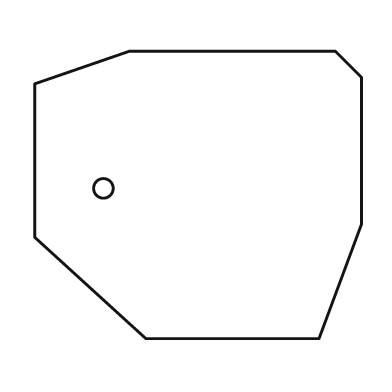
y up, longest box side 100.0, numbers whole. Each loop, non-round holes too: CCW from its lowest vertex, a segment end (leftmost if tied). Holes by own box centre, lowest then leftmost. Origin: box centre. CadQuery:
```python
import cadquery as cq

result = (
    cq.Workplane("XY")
    .moveTo(-16.0, -44.0)
    .lineTo(37.0, -44.0)
    .lineTo(50.0, -9.0)
    .lineTo(50.0, 36.0)
    .lineTo(42.0, 44.0)
    .lineTo(-21.0, 44.0)
    .lineTo(-50.0, 34.0)
    .lineTo(-50.0, -13.0)
    .close()
    .moveTo(-29.0, 2.0)
    .circle(3.0)
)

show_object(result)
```